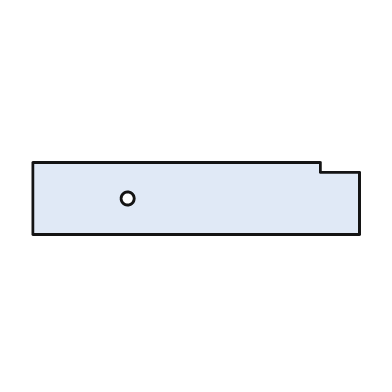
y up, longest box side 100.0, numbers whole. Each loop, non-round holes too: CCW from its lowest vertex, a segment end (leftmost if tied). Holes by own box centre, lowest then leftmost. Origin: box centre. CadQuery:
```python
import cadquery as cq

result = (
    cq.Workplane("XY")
    .moveTo(-50.0, -11.0)
    .lineTo(50.0, -11.0)
    .lineTo(50.0, 8.0)
    .lineTo(38.0, 8.0)
    .lineTo(38.0, 11.0)
    .lineTo(-50.0, 11.0)
    .close()
    .moveTo(-21.0, 0.0)
    .circle(2.0)
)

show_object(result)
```